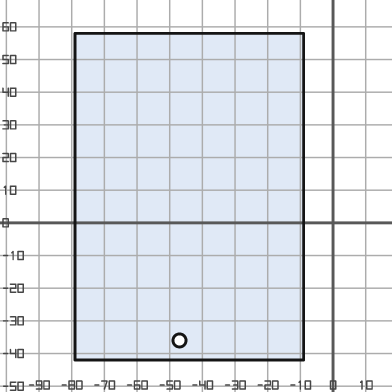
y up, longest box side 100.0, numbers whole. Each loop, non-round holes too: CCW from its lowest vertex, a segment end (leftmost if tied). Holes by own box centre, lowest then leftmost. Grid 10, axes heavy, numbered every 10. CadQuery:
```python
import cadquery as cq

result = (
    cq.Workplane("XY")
    .moveTo(-79.0, -42.0)
    .lineTo(-9.0, -42.0)
    .lineTo(-9.0, 58.0)
    .lineTo(-79.0, 58.0)
    .close()
    .moveTo(-47.0, -36.0)
    .circle(2.0)
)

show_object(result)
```